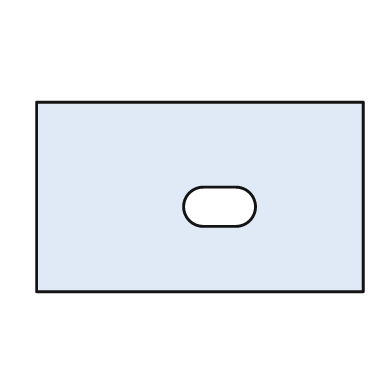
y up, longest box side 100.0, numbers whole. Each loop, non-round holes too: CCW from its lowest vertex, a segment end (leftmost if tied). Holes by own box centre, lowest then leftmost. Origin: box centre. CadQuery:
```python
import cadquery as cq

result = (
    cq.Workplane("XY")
    .moveTo(-50.0, -29.0)
    .lineTo(50.0, -29.0)
    .lineTo(50.0, 29.0)
    .lineTo(-50.0, 29.0)
    .close()
    .moveTo(1.0, -9.0)
    .lineTo(11.0, -9.0)
    .threePointArc((17.0, -3.0), (11.0, 3.0))
    .lineTo(1.0, 3.0)
    .threePointArc((-5.0, -3.0), (1.0, -9.0))
    .close()
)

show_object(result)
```